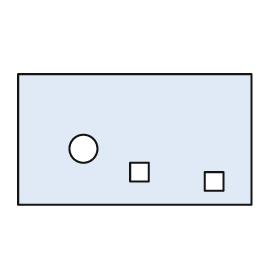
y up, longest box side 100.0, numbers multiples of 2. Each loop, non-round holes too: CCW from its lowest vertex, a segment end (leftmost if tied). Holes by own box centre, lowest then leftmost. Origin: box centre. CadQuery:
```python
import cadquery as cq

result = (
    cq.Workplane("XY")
    .moveTo(-50.0, -28.0)
    .lineTo(50.0, -28.0)
    .lineTo(50.0, 28.0)
    .lineTo(-50.0, 28.0)
    .close()
    .moveTo(30.0, -22.0)
    .lineTo(38.0, -22.0)
    .lineTo(38.0, -14.0)
    .lineTo(30.0, -14.0)
    .close()
    .moveTo(-2.0, -18.0)
    .lineTo(6.0, -18.0)
    .lineTo(6.0, -10.0)
    .lineTo(-2.0, -10.0)
    .close()
    .moveTo(-22.0, -4.0)
    .circle(6.0)
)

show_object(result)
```